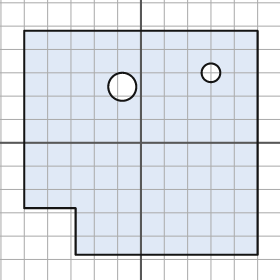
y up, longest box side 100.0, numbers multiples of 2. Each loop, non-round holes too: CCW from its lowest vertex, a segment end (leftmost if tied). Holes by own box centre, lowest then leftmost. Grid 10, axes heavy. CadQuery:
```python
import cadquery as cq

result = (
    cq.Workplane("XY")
    .moveTo(-28.0, -48.0)
    .lineTo(50.0, -48.0)
    .lineTo(50.0, 48.0)
    .lineTo(-50.0, 48.0)
    .lineTo(-50.0, -28.0)
    .lineTo(-28.0, -28.0)
    .close()
    .moveTo(-8.0, 24.0)
    .circle(6.0)
    .moveTo(30.0, 30.0)
    .circle(4.0)
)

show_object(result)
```